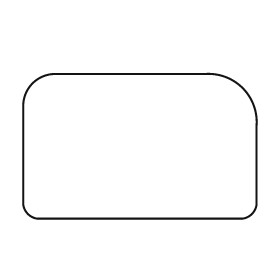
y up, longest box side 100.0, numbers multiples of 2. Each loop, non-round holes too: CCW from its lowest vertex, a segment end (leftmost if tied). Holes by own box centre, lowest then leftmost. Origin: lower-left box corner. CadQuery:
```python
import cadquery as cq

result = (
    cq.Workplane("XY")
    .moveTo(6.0, 0.0)
    .lineTo(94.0, 0.0)
    .threePointArc((98.0, 2.0), (100.0, 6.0))
    .lineTo(100.0, 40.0)
    .threePointArc((94.0, 56.0), (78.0, 62.0))
    .lineTo(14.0, 62.0)
    .threePointArc((4.0, 58.0), (0.0, 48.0))
    .lineTo(0.0, 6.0)
    .threePointArc((2.0, 2.0), (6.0, 0.0))
    .close()
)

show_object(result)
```